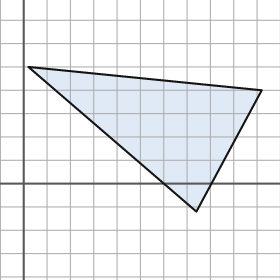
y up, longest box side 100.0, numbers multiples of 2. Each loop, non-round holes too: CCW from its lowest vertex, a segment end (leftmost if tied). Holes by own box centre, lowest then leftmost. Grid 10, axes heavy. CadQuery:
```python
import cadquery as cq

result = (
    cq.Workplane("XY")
    .moveTo(74.0, -12.0)
    .lineTo(102.0, 40.0)
    .lineTo(2.0, 50.0)
    .close()
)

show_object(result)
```